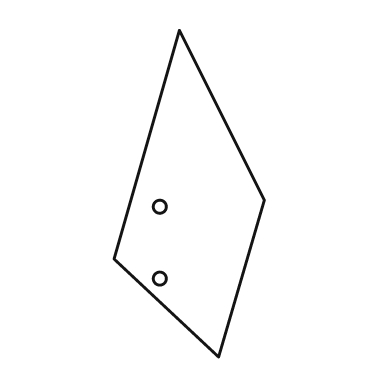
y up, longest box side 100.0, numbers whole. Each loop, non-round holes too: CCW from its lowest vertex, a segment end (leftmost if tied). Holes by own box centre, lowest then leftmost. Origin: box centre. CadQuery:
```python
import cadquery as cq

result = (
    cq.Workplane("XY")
    .moveTo(9.0, -50.0)
    .lineTo(23.0, -2.0)
    .lineTo(-3.0, 50.0)
    .lineTo(-23.0, -20.0)
    .close()
    .moveTo(-9.0, -26.0)
    .circle(2.0)
    .moveTo(-9.0, -4.0)
    .circle(2.0)
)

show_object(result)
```